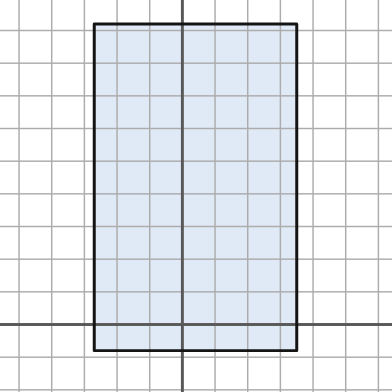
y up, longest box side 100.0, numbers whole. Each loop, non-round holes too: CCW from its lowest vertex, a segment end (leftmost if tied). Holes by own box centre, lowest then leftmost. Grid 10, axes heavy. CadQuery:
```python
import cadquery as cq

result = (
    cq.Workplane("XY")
    .moveTo(-27.0, -8.0)
    .lineTo(35.0, -8.0)
    .lineTo(35.0, 92.0)
    .lineTo(-27.0, 92.0)
    .close()
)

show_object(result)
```